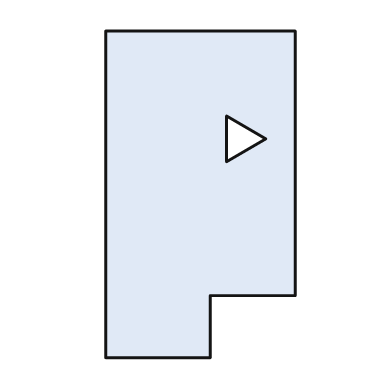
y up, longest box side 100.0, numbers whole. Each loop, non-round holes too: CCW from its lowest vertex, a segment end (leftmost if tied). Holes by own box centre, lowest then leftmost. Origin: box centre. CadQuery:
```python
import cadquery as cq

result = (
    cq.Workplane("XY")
    .moveTo(-29.0, -50.0)
    .lineTo(3.0, -50.0)
    .lineTo(3.0, -31.0)
    .lineTo(29.0, -31.0)
    .lineTo(29.0, 50.0)
    .lineTo(-29.0, 50.0)
    .close()
    .moveTo(8.0, 10.0)
    .lineTo(20.0, 17.0)
    .lineTo(8.0, 24.0)
    .close()
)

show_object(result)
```